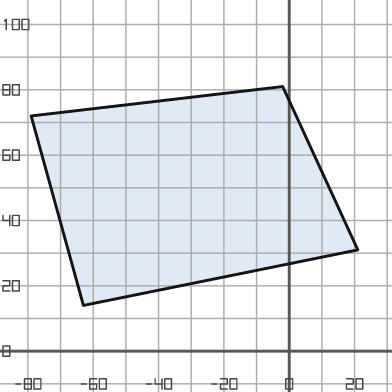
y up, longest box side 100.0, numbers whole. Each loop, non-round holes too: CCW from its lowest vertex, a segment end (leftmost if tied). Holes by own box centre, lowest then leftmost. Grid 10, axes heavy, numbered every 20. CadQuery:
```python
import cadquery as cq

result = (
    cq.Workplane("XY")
    .moveTo(-63.0, 14.0)
    .lineTo(21.0, 31.0)
    .lineTo(-2.0, 81.0)
    .lineTo(-79.0, 72.0)
    .close()
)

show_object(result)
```